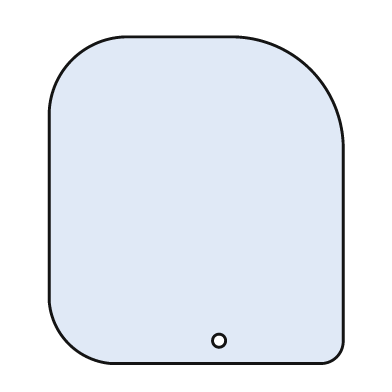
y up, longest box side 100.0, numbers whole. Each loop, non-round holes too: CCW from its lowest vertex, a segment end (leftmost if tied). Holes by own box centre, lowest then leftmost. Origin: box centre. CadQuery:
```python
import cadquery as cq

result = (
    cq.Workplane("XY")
    .moveTo(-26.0, -50.0)
    .lineTo(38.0, -50.0)
    .threePointArc((43.0, -48.0), (45.0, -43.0))
    .lineTo(45.0, 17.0)
    .threePointArc((35.0, 40.0), (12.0, 50.0))
    .lineTo(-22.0, 50.0)
    .threePointArc((-38.0, 43.0), (-45.0, 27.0))
    .lineTo(-45.0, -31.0)
    .threePointArc((-39.0, -44.0), (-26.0, -50.0))
    .close()
    .moveTo(7.0, -43.0)
    .circle(2.0)
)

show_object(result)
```